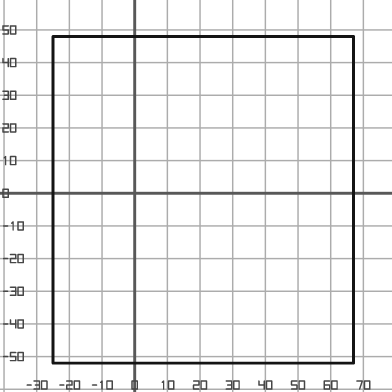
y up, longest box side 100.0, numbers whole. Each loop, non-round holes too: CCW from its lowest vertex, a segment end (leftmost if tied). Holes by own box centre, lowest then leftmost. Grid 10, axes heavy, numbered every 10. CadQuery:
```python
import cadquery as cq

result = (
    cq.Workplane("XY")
    .moveTo(-25.0, -52.0)
    .lineTo(67.0, -52.0)
    .lineTo(67.0, 48.0)
    .lineTo(-25.0, 48.0)
    .close()
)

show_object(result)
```